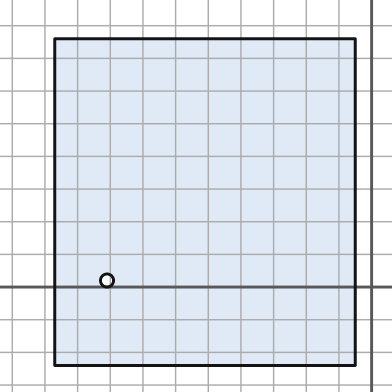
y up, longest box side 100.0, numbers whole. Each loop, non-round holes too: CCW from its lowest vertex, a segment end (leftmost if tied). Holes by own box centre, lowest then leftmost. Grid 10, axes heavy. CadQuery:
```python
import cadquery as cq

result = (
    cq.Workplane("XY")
    .moveTo(-97.0, -24.0)
    .lineTo(-5.0, -24.0)
    .lineTo(-5.0, 76.0)
    .lineTo(-97.0, 76.0)
    .close()
    .moveTo(-81.0, 2.0)
    .circle(2.0)
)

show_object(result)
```